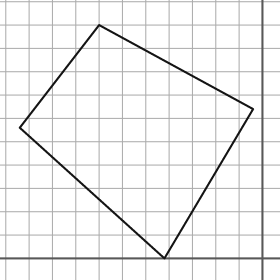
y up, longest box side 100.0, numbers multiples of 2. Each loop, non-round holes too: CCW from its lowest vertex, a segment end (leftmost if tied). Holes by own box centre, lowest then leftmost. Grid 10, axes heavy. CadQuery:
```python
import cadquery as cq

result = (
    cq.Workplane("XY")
    .moveTo(-42.0, 0.0)
    .lineTo(-4.0, 64.0)
    .lineTo(-70.0, 100.0)
    .lineTo(-104.0, 56.0)
    .close()
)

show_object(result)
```